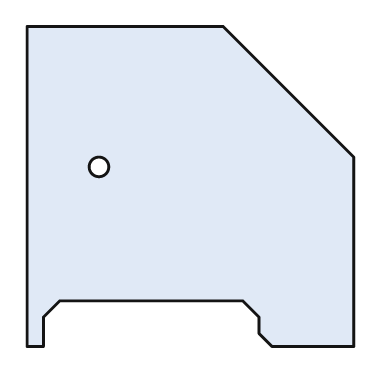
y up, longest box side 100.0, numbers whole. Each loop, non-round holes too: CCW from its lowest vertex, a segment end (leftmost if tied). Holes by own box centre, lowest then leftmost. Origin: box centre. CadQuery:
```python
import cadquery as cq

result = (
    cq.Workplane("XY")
    .moveTo(-50.0, -49.0)
    .lineTo(-45.0, -49.0)
    .lineTo(-45.0, -40.0)
    .lineTo(-40.0, -35.0)
    .lineTo(16.0, -35.0)
    .lineTo(21.0, -40.0)
    .lineTo(21.0, -45.0)
    .lineTo(25.0, -49.0)
    .lineTo(50.0, -49.0)
    .lineTo(50.0, 9.0)
    .lineTo(10.0, 49.0)
    .lineTo(-50.0, 49.0)
    .close()
    .moveTo(-28.0, 6.0)
    .circle(3.0)
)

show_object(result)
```